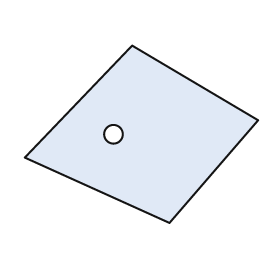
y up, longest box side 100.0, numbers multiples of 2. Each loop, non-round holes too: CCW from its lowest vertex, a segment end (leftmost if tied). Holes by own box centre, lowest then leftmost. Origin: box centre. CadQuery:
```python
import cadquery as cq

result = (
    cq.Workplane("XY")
    .moveTo(12.0, -38.0)
    .lineTo(50.0, 6.0)
    .lineTo(-4.0, 38.0)
    .lineTo(-50.0, -10.0)
    .close()
    .moveTo(-12.0, 0.0)
    .circle(4.0)
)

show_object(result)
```